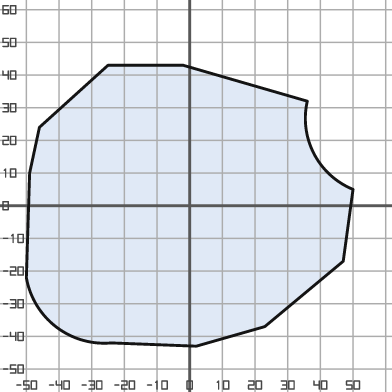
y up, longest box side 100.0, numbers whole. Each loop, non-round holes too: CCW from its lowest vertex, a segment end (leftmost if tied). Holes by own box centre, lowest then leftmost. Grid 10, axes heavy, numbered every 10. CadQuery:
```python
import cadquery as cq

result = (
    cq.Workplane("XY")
    .moveTo(2.0, -43.0)
    .lineTo(23.0, -37.0)
    .lineTo(47.0, -17.0)
    .lineTo(50.0, 5.0)
    .threePointArc((38.0, 16.0), (36.0, 32.0))
    .lineTo(-2.0, 43.0)
    .lineTo(-25.0, 43.0)
    .lineTo(-46.0, 24.0)
    .lineTo(-49.0, 10.0)
    .lineTo(-50.0, -22.0)
    .threePointArc((-41.0, -37.0), (-24.0, -42.0))
    .close()
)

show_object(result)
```